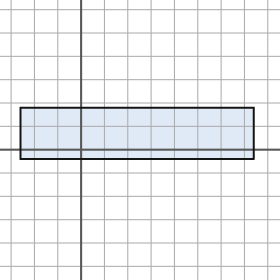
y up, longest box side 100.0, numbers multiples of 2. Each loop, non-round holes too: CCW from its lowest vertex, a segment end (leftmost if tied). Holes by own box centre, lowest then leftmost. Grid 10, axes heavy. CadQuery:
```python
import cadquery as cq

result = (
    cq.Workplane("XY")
    .moveTo(-26.0, -4.0)
    .lineTo(74.0, -4.0)
    .lineTo(74.0, 18.0)
    .lineTo(-26.0, 18.0)
    .close()
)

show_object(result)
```